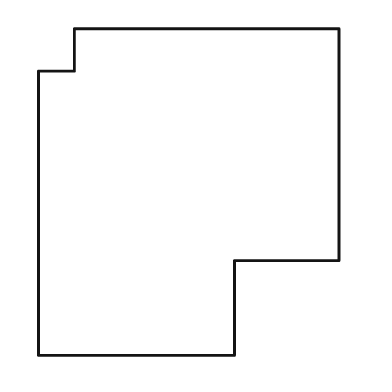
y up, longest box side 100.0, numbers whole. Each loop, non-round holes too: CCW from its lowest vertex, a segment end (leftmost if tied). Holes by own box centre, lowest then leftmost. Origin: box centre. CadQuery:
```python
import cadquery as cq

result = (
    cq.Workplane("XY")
    .moveTo(-46.0, -50.0)
    .lineTo(14.0, -50.0)
    .lineTo(14.0, -21.0)
    .lineTo(46.0, -21.0)
    .lineTo(46.0, 50.0)
    .lineTo(-35.0, 50.0)
    .lineTo(-35.0, 37.0)
    .lineTo(-46.0, 37.0)
    .close()
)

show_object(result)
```